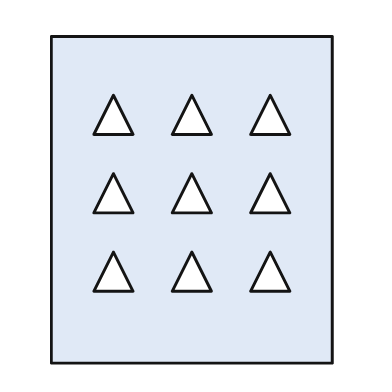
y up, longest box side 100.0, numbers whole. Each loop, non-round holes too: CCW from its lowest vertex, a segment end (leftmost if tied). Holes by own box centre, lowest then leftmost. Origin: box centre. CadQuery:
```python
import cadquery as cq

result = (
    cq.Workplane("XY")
    .moveTo(-43.0, -50.0)
    .lineTo(43.0, -50.0)
    .lineTo(43.0, 50.0)
    .lineTo(-43.0, 50.0)
    .close()
    .moveTo(-30.0, -28.0)
    .lineTo(-18.0, -28.0)
    .lineTo(-24.0, -16.0)
    .close()
    .moveTo(-6.0, -28.0)
    .lineTo(6.0, -28.0)
    .lineTo(0.0, -16.0)
    .close()
    .moveTo(18.0, -28.0)
    .lineTo(30.0, -28.0)
    .lineTo(24.0, -16.0)
    .close()
    .moveTo(-30.0, -4.0)
    .lineTo(-18.0, -4.0)
    .lineTo(-24.0, 8.0)
    .close()
    .moveTo(-6.0, -4.0)
    .lineTo(6.0, -4.0)
    .lineTo(0.0, 8.0)
    .close()
    .moveTo(18.0, -4.0)
    .lineTo(30.0, -4.0)
    .lineTo(24.0, 8.0)
    .close()
    .moveTo(-30.0, 20.0)
    .lineTo(-18.0, 20.0)
    .lineTo(-24.0, 32.0)
    .close()
    .moveTo(-6.0, 20.0)
    .lineTo(6.0, 20.0)
    .lineTo(0.0, 32.0)
    .close()
    .moveTo(18.0, 20.0)
    .lineTo(30.0, 20.0)
    .lineTo(24.0, 32.0)
    .close()
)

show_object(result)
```